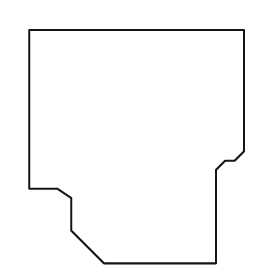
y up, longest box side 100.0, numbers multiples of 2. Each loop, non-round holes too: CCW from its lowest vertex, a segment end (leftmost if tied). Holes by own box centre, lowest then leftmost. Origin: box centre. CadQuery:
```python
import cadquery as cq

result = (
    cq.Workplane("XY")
    .moveTo(-14.0, -50.0)
    .lineTo(34.0, -50.0)
    .lineTo(34.0, -10.0)
    .lineTo(38.0, -6.0)
    .lineTo(42.0, -6.0)
    .lineTo(46.0, -2.0)
    .lineTo(46.0, 50.0)
    .lineTo(-46.0, 50.0)
    .lineTo(-46.0, -18.0)
    .lineTo(-34.0, -18.0)
    .lineTo(-28.0, -22.0)
    .lineTo(-28.0, -36.0)
    .close()
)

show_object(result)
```